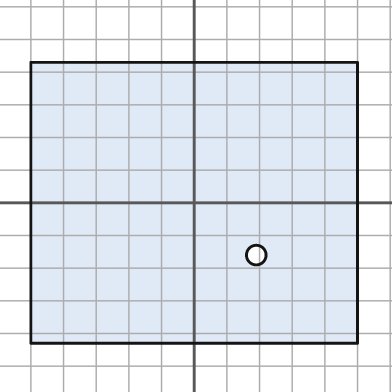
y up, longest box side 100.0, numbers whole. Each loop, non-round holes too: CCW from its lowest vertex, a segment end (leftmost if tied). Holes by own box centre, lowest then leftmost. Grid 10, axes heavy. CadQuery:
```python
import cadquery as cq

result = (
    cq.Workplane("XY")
    .moveTo(-50.0, -43.0)
    .lineTo(50.0, -43.0)
    .lineTo(50.0, 43.0)
    .lineTo(-50.0, 43.0)
    .close()
    .moveTo(19.0, -16.0)
    .circle(3.0)
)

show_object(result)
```